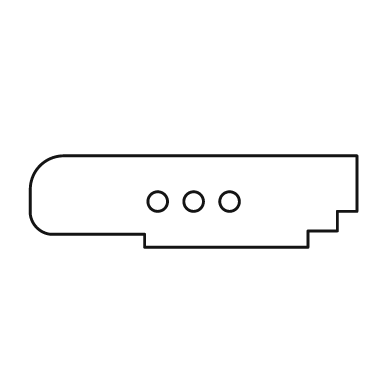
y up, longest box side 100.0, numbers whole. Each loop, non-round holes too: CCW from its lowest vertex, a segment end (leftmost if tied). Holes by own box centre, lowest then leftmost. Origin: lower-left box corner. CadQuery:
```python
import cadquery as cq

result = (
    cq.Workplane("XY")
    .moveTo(35.0, 0.0)
    .lineTo(85.0, 0.0)
    .lineTo(85.0, 5.0)
    .lineTo(94.0, 5.0)
    .lineTo(94.0, 11.0)
    .lineTo(100.0, 11.0)
    .lineTo(100.0, 28.0)
    .lineTo(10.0, 28.0)
    .threePointArc((3.0, 25.0), (0.0, 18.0))
    .lineTo(0.0, 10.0)
    .threePointArc((2.0, 6.0), (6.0, 4.0))
    .lineTo(35.0, 4.0)
    .close()
    .moveTo(39.0, 14.0)
    .circle(3.0)
    .moveTo(50.0, 14.0)
    .circle(3.0)
    .moveTo(61.0, 14.0)
    .circle(3.0)
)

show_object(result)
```